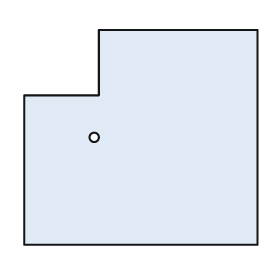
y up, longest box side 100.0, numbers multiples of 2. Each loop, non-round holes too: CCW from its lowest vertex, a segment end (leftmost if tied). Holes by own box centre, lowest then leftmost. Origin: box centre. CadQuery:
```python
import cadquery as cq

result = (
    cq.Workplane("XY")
    .moveTo(-50.0, -46.0)
    .lineTo(50.0, -46.0)
    .lineTo(50.0, 46.0)
    .lineTo(-18.0, 46.0)
    .lineTo(-18.0, 18.0)
    .lineTo(-50.0, 18.0)
    .close()
    .moveTo(-20.0, 0.0)
    .circle(2.0)
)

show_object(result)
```